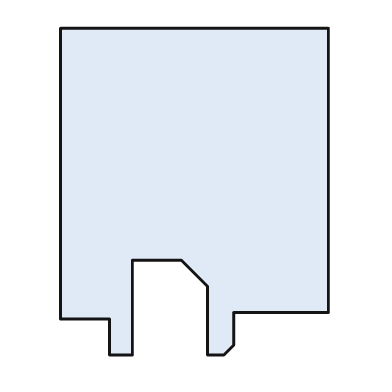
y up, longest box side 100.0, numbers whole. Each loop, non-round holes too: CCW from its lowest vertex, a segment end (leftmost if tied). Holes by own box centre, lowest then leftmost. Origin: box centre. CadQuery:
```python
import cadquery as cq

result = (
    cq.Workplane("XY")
    .moveTo(-26.0, -50.0)
    .lineTo(-19.0, -50.0)
    .lineTo(-19.0, -21.0)
    .lineTo(-4.0, -21.0)
    .lineTo(4.0, -29.0)
    .lineTo(4.0, -50.0)
    .lineTo(9.0, -50.0)
    .lineTo(12.0, -47.0)
    .lineTo(12.0, -37.0)
    .lineTo(41.0, -37.0)
    .lineTo(41.0, 50.0)
    .lineTo(-41.0, 50.0)
    .lineTo(-41.0, -39.0)
    .lineTo(-26.0, -39.0)
    .close()
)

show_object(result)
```